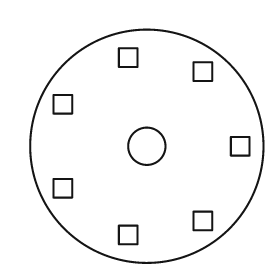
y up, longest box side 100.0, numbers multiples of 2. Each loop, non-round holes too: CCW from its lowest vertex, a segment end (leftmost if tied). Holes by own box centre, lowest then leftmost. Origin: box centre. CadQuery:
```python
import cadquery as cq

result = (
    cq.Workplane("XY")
    .moveTo(0.0, 0.0)
    .circle(50.0)
    .moveTo(-12.0, -42.0)
    .lineTo(-4.0, -42.0)
    .lineTo(-4.0, -34.0)
    .lineTo(-12.0, -34.0)
    .close()
    .moveTo(20.0, -36.0)
    .lineTo(28.0, -36.0)
    .lineTo(28.0, -28.0)
    .lineTo(20.0, -28.0)
    .close()
    .moveTo(-40.0, -22.0)
    .lineTo(-32.0, -22.0)
    .lineTo(-32.0, -14.0)
    .lineTo(-40.0, -14.0)
    .close()
    .moveTo(0.0, 0.0)
    .circle(8.0)
    .moveTo(36.0, -4.0)
    .lineTo(44.0, -4.0)
    .lineTo(44.0, 4.0)
    .lineTo(36.0, 4.0)
    .close()
    .moveTo(-40.0, 14.0)
    .lineTo(-32.0, 14.0)
    .lineTo(-32.0, 22.0)
    .lineTo(-40.0, 22.0)
    .close()
    .moveTo(20.0, 28.0)
    .lineTo(28.0, 28.0)
    .lineTo(28.0, 36.0)
    .lineTo(20.0, 36.0)
    .close()
    .moveTo(-12.0, 34.0)
    .lineTo(-4.0, 34.0)
    .lineTo(-4.0, 42.0)
    .lineTo(-12.0, 42.0)
    .close()
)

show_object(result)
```